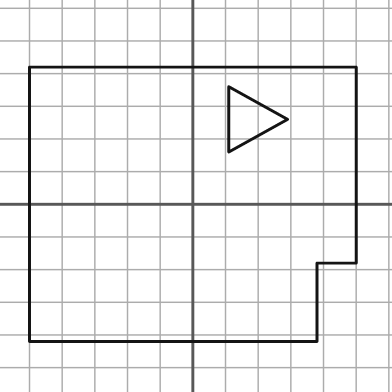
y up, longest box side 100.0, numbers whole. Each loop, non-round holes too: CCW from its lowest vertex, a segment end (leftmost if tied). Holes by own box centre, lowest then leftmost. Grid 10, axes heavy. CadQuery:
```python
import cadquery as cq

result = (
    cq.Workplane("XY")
    .moveTo(-50.0, -42.0)
    .lineTo(38.0, -42.0)
    .lineTo(38.0, -18.0)
    .lineTo(50.0, -18.0)
    .lineTo(50.0, 42.0)
    .lineTo(-50.0, 42.0)
    .close()
    .moveTo(11.0, 16.0)
    .lineTo(29.0, 26.0)
    .lineTo(11.0, 36.0)
    .close()
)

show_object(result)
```